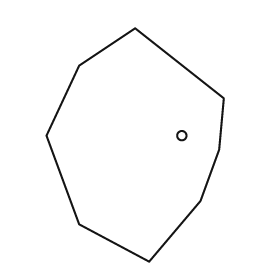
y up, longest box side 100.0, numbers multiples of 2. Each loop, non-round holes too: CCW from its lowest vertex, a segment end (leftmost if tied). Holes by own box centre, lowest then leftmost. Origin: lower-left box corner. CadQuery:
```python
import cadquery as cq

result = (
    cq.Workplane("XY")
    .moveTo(44.0, 0.0)
    .lineTo(66.0, 26.0)
    .lineTo(74.0, 48.0)
    .lineTo(76.0, 70.0)
    .lineTo(38.0, 100.0)
    .lineTo(14.0, 84.0)
    .lineTo(0.0, 54.0)
    .lineTo(14.0, 16.0)
    .close()
    .moveTo(58.0, 54.0)
    .circle(2.0)
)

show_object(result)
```